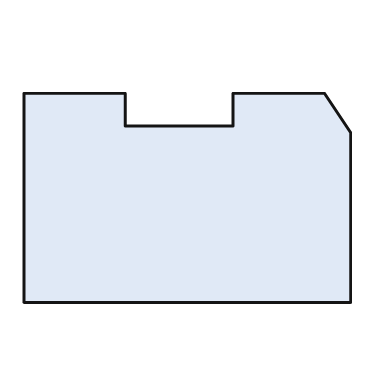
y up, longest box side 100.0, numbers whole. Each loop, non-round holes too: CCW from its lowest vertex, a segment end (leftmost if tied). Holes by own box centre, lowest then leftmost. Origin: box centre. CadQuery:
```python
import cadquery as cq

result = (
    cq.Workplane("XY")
    .moveTo(-50.0, -32.0)
    .lineTo(50.0, -32.0)
    .lineTo(50.0, 20.0)
    .lineTo(42.0, 32.0)
    .lineTo(14.0, 32.0)
    .lineTo(14.0, 22.0)
    .lineTo(-19.0, 22.0)
    .lineTo(-19.0, 32.0)
    .lineTo(-50.0, 32.0)
    .close()
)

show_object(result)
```